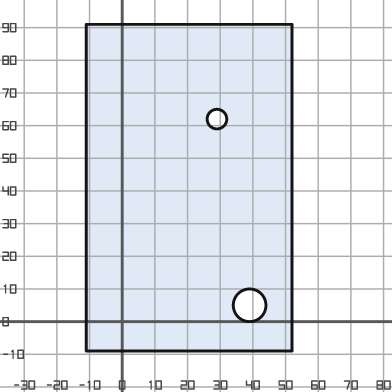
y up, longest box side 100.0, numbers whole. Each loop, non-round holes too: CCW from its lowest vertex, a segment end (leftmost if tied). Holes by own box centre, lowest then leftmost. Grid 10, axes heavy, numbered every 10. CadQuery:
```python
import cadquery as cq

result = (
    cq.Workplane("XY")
    .moveTo(-11.0, -9.0)
    .lineTo(52.0, -9.0)
    .lineTo(52.0, 91.0)
    .lineTo(-11.0, 91.0)
    .close()
    .moveTo(39.0, 5.0)
    .circle(5.0)
    .moveTo(29.0, 62.0)
    .circle(3.0)
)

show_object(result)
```